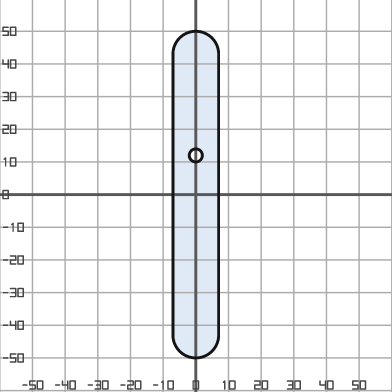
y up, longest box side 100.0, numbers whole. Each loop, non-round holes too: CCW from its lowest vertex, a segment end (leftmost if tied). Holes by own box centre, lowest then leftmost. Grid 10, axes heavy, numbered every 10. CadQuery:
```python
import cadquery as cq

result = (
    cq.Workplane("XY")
    .moveTo(-7.0, -43.0)
    .threePointArc((0.0, -50.0), (7.0, -43.0))
    .lineTo(7.0, 43.0)
    .threePointArc((0.0, 50.0), (-7.0, 43.0))
    .close()
    .moveTo(0.0, 12.0)
    .circle(2.0)
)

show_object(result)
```